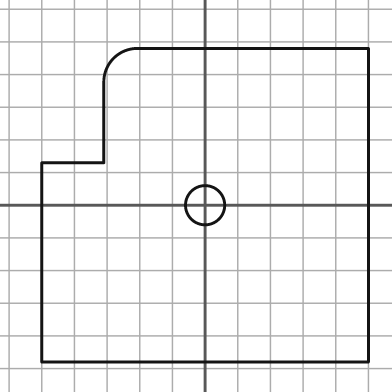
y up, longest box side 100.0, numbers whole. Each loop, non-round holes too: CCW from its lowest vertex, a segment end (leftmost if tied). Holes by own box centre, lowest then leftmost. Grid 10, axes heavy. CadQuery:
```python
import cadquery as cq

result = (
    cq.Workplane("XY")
    .moveTo(-50.0, -48.0)
    .lineTo(50.0, -48.0)
    .lineTo(50.0, 48.0)
    .lineTo(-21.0, 48.0)
    .threePointArc((-28.0, 45.0), (-31.0, 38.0))
    .lineTo(-31.0, 13.0)
    .lineTo(-50.0, 13.0)
    .close()
    .moveTo(0.0, 0.0)
    .circle(6.0)
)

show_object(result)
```